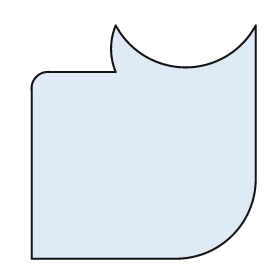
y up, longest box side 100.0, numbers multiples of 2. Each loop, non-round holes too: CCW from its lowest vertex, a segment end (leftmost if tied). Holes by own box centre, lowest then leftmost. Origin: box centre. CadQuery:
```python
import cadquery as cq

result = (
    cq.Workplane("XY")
    .moveTo(-48.0, -50.0)
    .lineTo(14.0, -50.0)
    .threePointArc((38.0, -40.0), (48.0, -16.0))
    .lineTo(48.0, 50.0)
    .threePointArc((18.0, 32.0), (-12.0, 50.0))
    .threePointArc((-14.0, 40.0), (-12.0, 30.0))
    .lineTo(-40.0, 30.0)
    .threePointArc((-46.0, 28.0), (-48.0, 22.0))
    .close()
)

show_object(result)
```